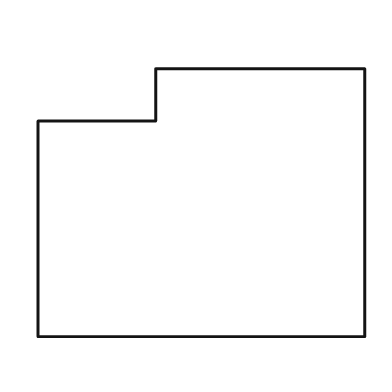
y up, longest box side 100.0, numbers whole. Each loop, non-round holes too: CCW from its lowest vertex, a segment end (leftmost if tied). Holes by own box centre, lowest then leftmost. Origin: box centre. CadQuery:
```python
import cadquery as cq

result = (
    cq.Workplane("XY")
    .moveTo(-50.0, -41.0)
    .lineTo(50.0, -41.0)
    .lineTo(50.0, 41.0)
    .lineTo(-14.0, 41.0)
    .lineTo(-14.0, 25.0)
    .lineTo(-50.0, 25.0)
    .close()
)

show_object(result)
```